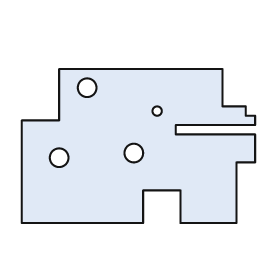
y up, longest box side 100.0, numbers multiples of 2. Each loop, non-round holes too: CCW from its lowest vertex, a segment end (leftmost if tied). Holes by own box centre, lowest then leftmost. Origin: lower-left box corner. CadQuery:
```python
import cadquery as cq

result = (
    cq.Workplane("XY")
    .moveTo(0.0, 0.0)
    .lineTo(52.0, 0.0)
    .lineTo(52.0, 14.0)
    .lineTo(68.0, 14.0)
    .lineTo(68.0, 0.0)
    .lineTo(92.0, 0.0)
    .lineTo(92.0, 26.0)
    .lineTo(100.0, 26.0)
    .lineTo(100.0, 38.0)
    .lineTo(66.0, 38.0)
    .lineTo(66.0, 42.0)
    .lineTo(100.0, 42.0)
    .lineTo(100.0, 46.0)
    .lineTo(96.0, 46.0)
    .lineTo(96.0, 50.0)
    .lineTo(86.0, 50.0)
    .lineTo(86.0, 66.0)
    .lineTo(16.0, 66.0)
    .lineTo(16.0, 44.0)
    .lineTo(0.0, 44.0)
    .close()
    .moveTo(16.0, 28.0)
    .circle(4.0)
    .moveTo(48.0, 30.0)
    .circle(4.0)
    .moveTo(58.0, 48.0)
    .circle(2.0)
    .moveTo(28.0, 58.0)
    .circle(4.0)
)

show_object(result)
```